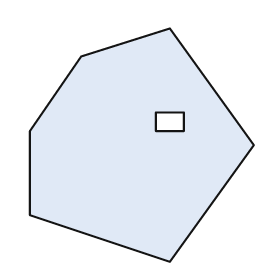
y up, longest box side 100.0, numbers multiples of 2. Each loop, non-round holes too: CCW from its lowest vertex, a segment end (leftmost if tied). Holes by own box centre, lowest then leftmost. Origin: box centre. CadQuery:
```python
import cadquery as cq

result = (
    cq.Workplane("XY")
    .moveTo(12.0, -50.0)
    .lineTo(48.0, 0.0)
    .lineTo(12.0, 50.0)
    .lineTo(-26.0, 38.0)
    .lineTo(-48.0, 6.0)
    .lineTo(-48.0, -30.0)
    .close()
    .moveTo(6.0, 6.0)
    .lineTo(18.0, 6.0)
    .lineTo(18.0, 14.0)
    .lineTo(6.0, 14.0)
    .close()
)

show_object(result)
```